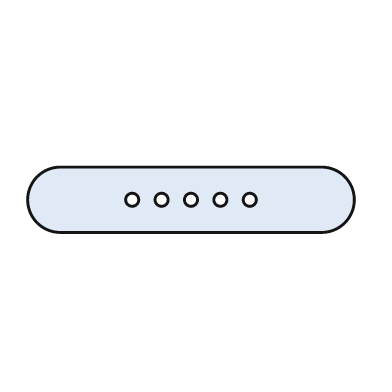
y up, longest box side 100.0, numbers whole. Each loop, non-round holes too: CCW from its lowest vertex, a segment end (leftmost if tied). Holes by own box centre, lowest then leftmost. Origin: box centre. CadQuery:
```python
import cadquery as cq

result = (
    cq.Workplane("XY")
    .moveTo(-40.0, -10.0)
    .lineTo(40.0, -10.0)
    .threePointArc((50.0, 0.0), (40.0, 10.0))
    .lineTo(-40.0, 10.0)
    .threePointArc((-50.0, 0.0), (-40.0, -10.0))
    .close()
    .moveTo(-18.0, 0.0)
    .circle(2.0)
    .moveTo(-9.0, 0.0)
    .circle(2.0)
    .moveTo(0.0, 0.0)
    .circle(2.0)
    .moveTo(9.0, 0.0)
    .circle(2.0)
    .moveTo(18.0, 0.0)
    .circle(2.0)
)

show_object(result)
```